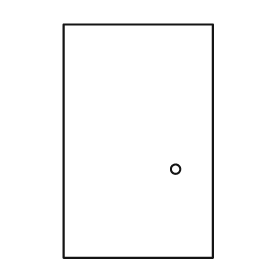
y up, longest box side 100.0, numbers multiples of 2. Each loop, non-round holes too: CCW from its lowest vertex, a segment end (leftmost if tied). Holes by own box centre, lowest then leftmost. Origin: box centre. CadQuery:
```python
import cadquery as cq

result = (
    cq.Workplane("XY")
    .moveTo(-32.0, -50.0)
    .lineTo(32.0, -50.0)
    .lineTo(32.0, 50.0)
    .lineTo(-32.0, 50.0)
    .close()
    .moveTo(16.0, -12.0)
    .circle(2.0)
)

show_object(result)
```